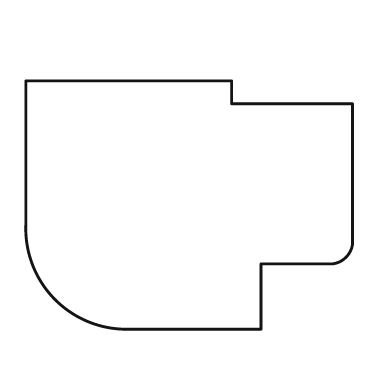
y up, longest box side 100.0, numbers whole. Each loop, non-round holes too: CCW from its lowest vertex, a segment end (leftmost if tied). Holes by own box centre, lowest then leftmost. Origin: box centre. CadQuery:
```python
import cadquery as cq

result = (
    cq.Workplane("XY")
    .moveTo(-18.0, -38.0)
    .lineTo(22.0, -38.0)
    .lineTo(22.0, -18.0)
    .lineTo(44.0, -18.0)
    .threePointArc((48.0, -16.0), (50.0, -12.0))
    .lineTo(50.0, 31.0)
    .lineTo(13.0, 31.0)
    .lineTo(13.0, 38.0)
    .lineTo(-50.0, 38.0)
    .lineTo(-50.0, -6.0)
    .threePointArc((-41.0, -29.0), (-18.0, -38.0))
    .close()
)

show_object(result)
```